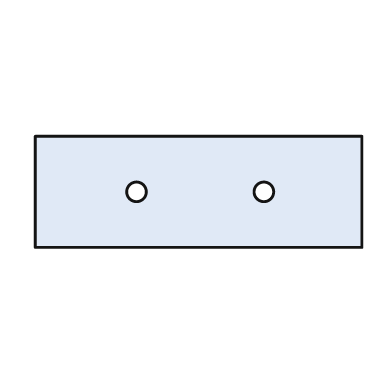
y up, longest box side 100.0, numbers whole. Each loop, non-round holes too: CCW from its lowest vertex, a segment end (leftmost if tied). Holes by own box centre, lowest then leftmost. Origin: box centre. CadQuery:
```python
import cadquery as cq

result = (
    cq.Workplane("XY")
    .moveTo(-50.0, -17.0)
    .lineTo(50.0, -17.0)
    .lineTo(50.0, 17.0)
    .lineTo(-50.0, 17.0)
    .close()
    .moveTo(-19.0, 0.0)
    .circle(3.0)
    .moveTo(20.0, 0.0)
    .circle(3.0)
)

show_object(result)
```